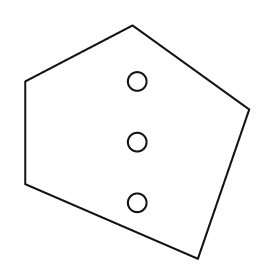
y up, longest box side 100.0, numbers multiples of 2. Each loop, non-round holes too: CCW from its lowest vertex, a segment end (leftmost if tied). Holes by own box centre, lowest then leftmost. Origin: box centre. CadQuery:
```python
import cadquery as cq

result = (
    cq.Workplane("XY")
    .moveTo(26.0, -50.0)
    .lineTo(48.0, 14.0)
    .lineTo(-2.0, 50.0)
    .lineTo(-48.0, 26.0)
    .lineTo(-48.0, -18.0)
    .close()
    .moveTo(0.0, -26.0)
    .circle(4.0)
    .moveTo(0.0, 0.0)
    .circle(4.0)
    .moveTo(0.0, 26.0)
    .circle(4.0)
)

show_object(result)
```